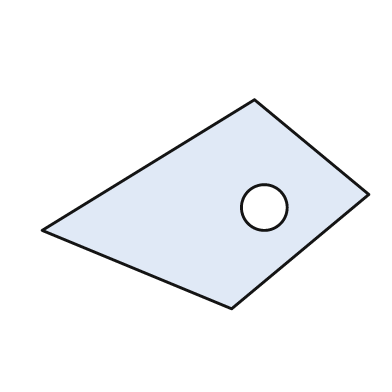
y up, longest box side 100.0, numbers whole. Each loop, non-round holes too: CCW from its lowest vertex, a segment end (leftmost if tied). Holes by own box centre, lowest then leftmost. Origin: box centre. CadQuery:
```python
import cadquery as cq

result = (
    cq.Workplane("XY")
    .moveTo(8.0, -32.0)
    .lineTo(50.0, 3.0)
    .lineTo(15.0, 32.0)
    .lineTo(-50.0, -8.0)
    .close()
    .moveTo(18.0, -1.0)
    .circle(7.0)
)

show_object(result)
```